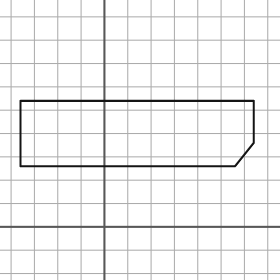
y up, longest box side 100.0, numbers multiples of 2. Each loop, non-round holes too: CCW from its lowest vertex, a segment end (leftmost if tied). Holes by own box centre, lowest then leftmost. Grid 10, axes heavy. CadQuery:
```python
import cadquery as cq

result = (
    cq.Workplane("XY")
    .moveTo(-36.0, 26.0)
    .lineTo(56.0, 26.0)
    .lineTo(64.0, 36.0)
    .lineTo(64.0, 54.0)
    .lineTo(-36.0, 54.0)
    .close()
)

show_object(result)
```